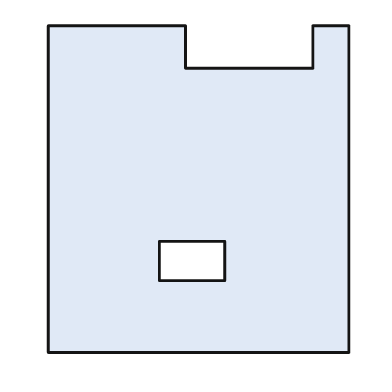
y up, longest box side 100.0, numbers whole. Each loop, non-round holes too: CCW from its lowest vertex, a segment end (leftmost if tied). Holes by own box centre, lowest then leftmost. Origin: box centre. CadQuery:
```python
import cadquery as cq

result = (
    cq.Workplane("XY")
    .moveTo(-46.0, -50.0)
    .lineTo(46.0, -50.0)
    .lineTo(46.0, 50.0)
    .lineTo(35.0, 50.0)
    .lineTo(35.0, 37.0)
    .lineTo(-4.0, 37.0)
    .lineTo(-4.0, 50.0)
    .lineTo(-46.0, 50.0)
    .close()
    .moveTo(-12.0, -28.0)
    .lineTo(8.0, -28.0)
    .lineTo(8.0, -16.0)
    .lineTo(-12.0, -16.0)
    .close()
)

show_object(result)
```